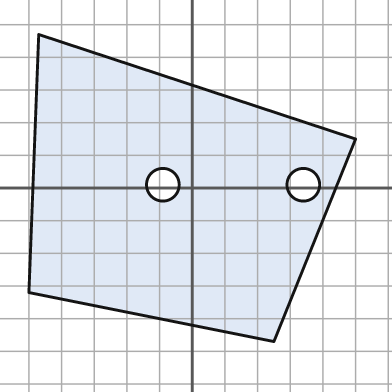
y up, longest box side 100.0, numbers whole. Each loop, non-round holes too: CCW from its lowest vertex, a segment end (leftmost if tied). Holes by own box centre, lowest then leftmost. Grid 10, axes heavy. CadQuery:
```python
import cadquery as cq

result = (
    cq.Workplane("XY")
    .moveTo(25.0, -47.0)
    .lineTo(50.0, 15.0)
    .lineTo(-47.0, 47.0)
    .lineTo(-50.0, -32.0)
    .close()
    .moveTo(-9.0, 1.0)
    .circle(5.0)
    .moveTo(34.0, 1.0)
    .circle(5.0)
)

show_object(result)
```